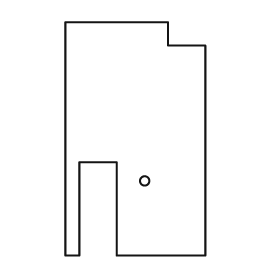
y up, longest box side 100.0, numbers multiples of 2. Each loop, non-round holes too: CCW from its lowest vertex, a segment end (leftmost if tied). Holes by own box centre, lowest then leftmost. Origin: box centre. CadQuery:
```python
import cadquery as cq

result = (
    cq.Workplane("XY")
    .moveTo(-30.0, -50.0)
    .lineTo(-24.0, -50.0)
    .lineTo(-24.0, -10.0)
    .lineTo(-8.0, -10.0)
    .lineTo(-8.0, -50.0)
    .lineTo(30.0, -50.0)
    .lineTo(30.0, 40.0)
    .lineTo(14.0, 40.0)
    .lineTo(14.0, 50.0)
    .lineTo(-30.0, 50.0)
    .close()
    .moveTo(4.0, -18.0)
    .circle(2.0)
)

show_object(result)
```